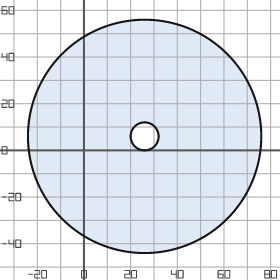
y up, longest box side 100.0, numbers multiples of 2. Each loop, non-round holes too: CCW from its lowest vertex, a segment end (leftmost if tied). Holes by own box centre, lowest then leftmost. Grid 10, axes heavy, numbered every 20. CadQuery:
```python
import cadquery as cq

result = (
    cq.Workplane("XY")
    .moveTo(26.0, 6.0)
    .circle(50.0)
    .moveTo(26.0, 6.0)
    .circle(6.0)
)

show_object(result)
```